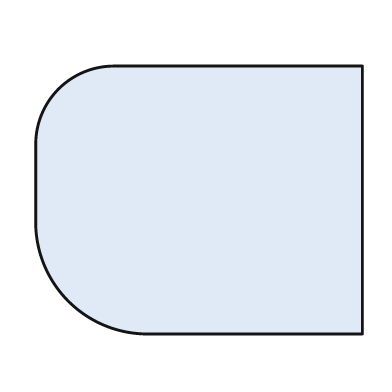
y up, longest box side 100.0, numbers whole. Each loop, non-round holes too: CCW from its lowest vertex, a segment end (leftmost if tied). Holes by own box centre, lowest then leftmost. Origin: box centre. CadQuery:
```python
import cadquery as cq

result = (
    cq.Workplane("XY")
    .moveTo(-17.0, -41.0)
    .lineTo(50.0, -41.0)
    .lineTo(50.0, 41.0)
    .lineTo(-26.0, 41.0)
    .threePointArc((-43.0, 34.0), (-50.0, 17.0))
    .lineTo(-50.0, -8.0)
    .threePointArc((-40.0, -31.0), (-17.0, -41.0))
    .close()
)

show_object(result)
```